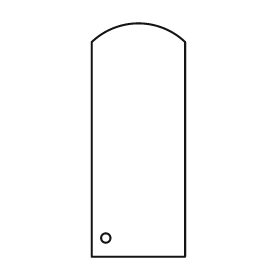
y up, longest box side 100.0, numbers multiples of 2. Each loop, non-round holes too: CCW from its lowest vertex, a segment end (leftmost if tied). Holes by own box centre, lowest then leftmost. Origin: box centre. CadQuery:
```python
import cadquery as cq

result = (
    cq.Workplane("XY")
    .moveTo(-20.0, -50.0)
    .lineTo(20.0, -50.0)
    .lineTo(20.0, 42.0)
    .threePointArc((0.0, 50.0), (-20.0, 42.0))
    .close()
    .moveTo(-14.0, -42.0)
    .circle(2.0)
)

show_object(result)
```